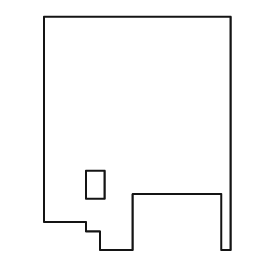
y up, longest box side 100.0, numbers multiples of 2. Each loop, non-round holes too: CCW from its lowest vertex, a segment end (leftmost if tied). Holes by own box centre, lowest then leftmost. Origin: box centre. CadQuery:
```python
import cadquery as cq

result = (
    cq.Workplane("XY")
    .moveTo(-16.0, -50.0)
    .lineTo(-2.0, -50.0)
    .lineTo(-2.0, -26.0)
    .lineTo(36.0, -26.0)
    .lineTo(36.0, -50.0)
    .lineTo(40.0, -50.0)
    .lineTo(40.0, 50.0)
    .lineTo(-40.0, 50.0)
    .lineTo(-40.0, -38.0)
    .lineTo(-22.0, -38.0)
    .lineTo(-22.0, -42.0)
    .lineTo(-16.0, -42.0)
    .close()
    .moveTo(-22.0, -28.0)
    .lineTo(-14.0, -28.0)
    .lineTo(-14.0, -16.0)
    .lineTo(-22.0, -16.0)
    .close()
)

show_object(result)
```